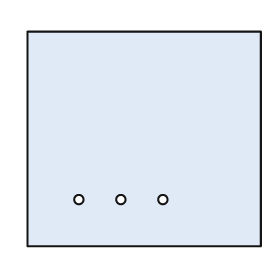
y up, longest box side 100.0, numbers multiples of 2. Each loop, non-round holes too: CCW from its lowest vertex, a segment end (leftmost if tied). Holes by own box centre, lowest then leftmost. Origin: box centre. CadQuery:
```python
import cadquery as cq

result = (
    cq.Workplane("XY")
    .moveTo(-50.0, -46.0)
    .lineTo(50.0, -46.0)
    .lineTo(50.0, 46.0)
    .lineTo(-50.0, 46.0)
    .close()
    .moveTo(-28.0, -26.0)
    .circle(2.0)
    .moveTo(-10.0, -26.0)
    .circle(2.0)
    .moveTo(8.0, -26.0)
    .circle(2.0)
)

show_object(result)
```